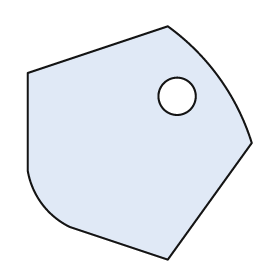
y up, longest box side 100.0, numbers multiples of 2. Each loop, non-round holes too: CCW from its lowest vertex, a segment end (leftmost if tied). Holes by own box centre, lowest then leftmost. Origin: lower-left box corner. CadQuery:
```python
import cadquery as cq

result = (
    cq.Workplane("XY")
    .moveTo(60.0, 0.0)
    .lineTo(96.0, 50.0)
    .threePointArc((82.0, 78.0), (60.0, 100.0))
    .lineTo(0.0, 80.0)
    .lineTo(0.0, 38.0)
    .threePointArc((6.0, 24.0), (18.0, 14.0))
    .close()
    .moveTo(64.0, 70.0)
    .circle(8.0)
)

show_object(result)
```